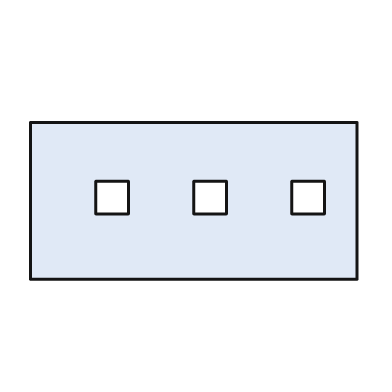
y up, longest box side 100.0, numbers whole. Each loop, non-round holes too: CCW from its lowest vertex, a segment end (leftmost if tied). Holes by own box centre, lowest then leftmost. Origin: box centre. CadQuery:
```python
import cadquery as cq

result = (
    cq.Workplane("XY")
    .moveTo(-50.0, -24.0)
    .lineTo(50.0, -24.0)
    .lineTo(50.0, 24.0)
    .lineTo(-50.0, 24.0)
    .close()
    .moveTo(-30.0, -4.0)
    .lineTo(-20.0, -4.0)
    .lineTo(-20.0, 6.0)
    .lineTo(-30.0, 6.0)
    .close()
    .moveTo(0.0, -4.0)
    .lineTo(10.0, -4.0)
    .lineTo(10.0, 6.0)
    .lineTo(0.0, 6.0)
    .close()
    .moveTo(30.0, -4.0)
    .lineTo(40.0, -4.0)
    .lineTo(40.0, 6.0)
    .lineTo(30.0, 6.0)
    .close()
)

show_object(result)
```